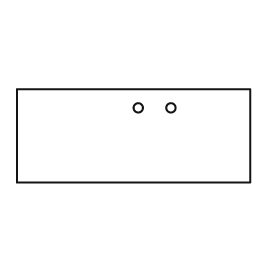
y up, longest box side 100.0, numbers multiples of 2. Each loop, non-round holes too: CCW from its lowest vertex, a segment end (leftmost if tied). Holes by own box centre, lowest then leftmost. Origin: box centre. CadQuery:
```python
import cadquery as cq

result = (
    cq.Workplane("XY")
    .moveTo(-50.0, -20.0)
    .lineTo(50.0, -20.0)
    .lineTo(50.0, 20.0)
    .lineTo(-50.0, 20.0)
    .close()
    .moveTo(2.0, 12.0)
    .circle(2.0)
    .moveTo(16.0, 12.0)
    .circle(2.0)
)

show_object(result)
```